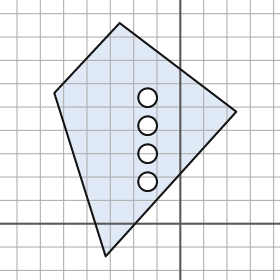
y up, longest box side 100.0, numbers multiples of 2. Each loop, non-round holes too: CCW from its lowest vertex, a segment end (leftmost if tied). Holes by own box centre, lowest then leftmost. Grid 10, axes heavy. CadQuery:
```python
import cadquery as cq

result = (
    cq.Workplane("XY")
    .moveTo(-32.0, -14.0)
    .lineTo(24.0, 48.0)
    .lineTo(-26.0, 86.0)
    .lineTo(-54.0, 56.0)
    .close()
    .moveTo(-14.0, 18.0)
    .circle(4.0)
    .moveTo(-14.0, 30.0)
    .circle(4.0)
    .moveTo(-14.0, 42.0)
    .circle(4.0)
    .moveTo(-14.0, 54.0)
    .circle(4.0)
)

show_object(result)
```